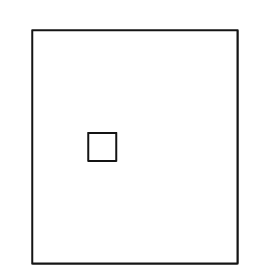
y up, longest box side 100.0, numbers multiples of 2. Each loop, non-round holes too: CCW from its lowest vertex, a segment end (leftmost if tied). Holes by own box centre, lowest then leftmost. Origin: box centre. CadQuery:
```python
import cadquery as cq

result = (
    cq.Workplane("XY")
    .moveTo(-44.0, -50.0)
    .lineTo(44.0, -50.0)
    .lineTo(44.0, 50.0)
    .lineTo(-44.0, 50.0)
    .close()
    .moveTo(-20.0, -6.0)
    .lineTo(-8.0, -6.0)
    .lineTo(-8.0, 6.0)
    .lineTo(-20.0, 6.0)
    .close()
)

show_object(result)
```